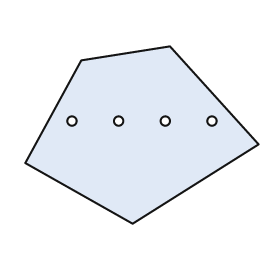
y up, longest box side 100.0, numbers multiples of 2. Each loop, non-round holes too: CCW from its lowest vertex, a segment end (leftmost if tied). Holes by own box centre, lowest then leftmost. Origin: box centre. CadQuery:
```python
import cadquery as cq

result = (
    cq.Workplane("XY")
    .moveTo(-4.0, -38.0)
    .lineTo(50.0, -4.0)
    .lineTo(12.0, 38.0)
    .lineTo(-26.0, 32.0)
    .lineTo(-50.0, -12.0)
    .close()
    .moveTo(-30.0, 6.0)
    .circle(2.0)
    .moveTo(-10.0, 6.0)
    .circle(2.0)
    .moveTo(10.0, 6.0)
    .circle(2.0)
    .moveTo(30.0, 6.0)
    .circle(2.0)
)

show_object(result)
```